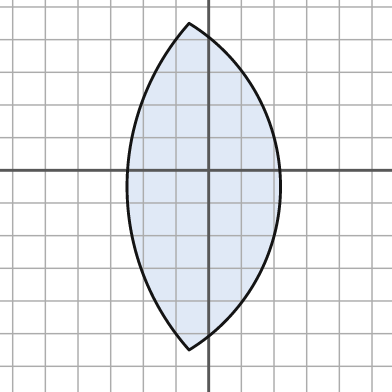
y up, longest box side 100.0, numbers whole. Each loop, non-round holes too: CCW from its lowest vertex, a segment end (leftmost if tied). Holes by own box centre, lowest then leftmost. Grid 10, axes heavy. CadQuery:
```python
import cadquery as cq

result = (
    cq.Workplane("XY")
    .moveTo(-6.0, -55.0)
    .threePointArc((22.0, -5.0), (-6.0, 45.0))
    .threePointArc((-25.0, -5.0), (-6.0, -55.0))
    .close()
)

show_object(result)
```